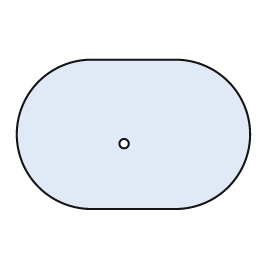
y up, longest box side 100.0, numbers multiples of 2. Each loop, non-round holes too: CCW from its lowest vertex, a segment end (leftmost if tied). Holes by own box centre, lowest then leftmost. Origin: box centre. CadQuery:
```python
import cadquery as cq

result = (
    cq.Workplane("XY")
    .moveTo(-18.0, -32.0)
    .lineTo(18.0, -32.0)
    .threePointArc((50.0, 0.0), (18.0, 32.0))
    .lineTo(-18.0, 32.0)
    .threePointArc((-50.0, 0.0), (-18.0, -32.0))
    .close()
    .moveTo(-4.0, -4.0)
    .circle(2.0)
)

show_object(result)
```